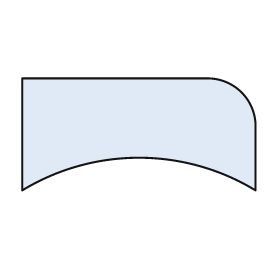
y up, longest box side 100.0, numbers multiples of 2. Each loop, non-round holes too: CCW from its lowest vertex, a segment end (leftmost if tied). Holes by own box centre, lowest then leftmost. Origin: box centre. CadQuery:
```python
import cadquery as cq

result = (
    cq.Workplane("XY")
    .moveTo(-50.0, -24.0)
    .threePointArc((0.0, -10.0), (50.0, -24.0))
    .lineTo(50.0, 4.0)
    .threePointArc((44.0, 18.0), (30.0, 24.0))
    .lineTo(-50.0, 24.0)
    .close()
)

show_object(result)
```